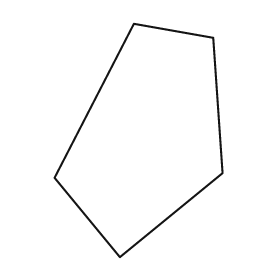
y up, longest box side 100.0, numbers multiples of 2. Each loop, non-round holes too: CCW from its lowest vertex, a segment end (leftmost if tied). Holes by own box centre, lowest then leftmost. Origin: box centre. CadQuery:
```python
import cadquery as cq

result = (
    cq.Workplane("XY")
    .moveTo(-8.0, -50.0)
    .lineTo(36.0, -14.0)
    .lineTo(32.0, 44.0)
    .lineTo(-2.0, 50.0)
    .lineTo(-36.0, -16.0)
    .close()
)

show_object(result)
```